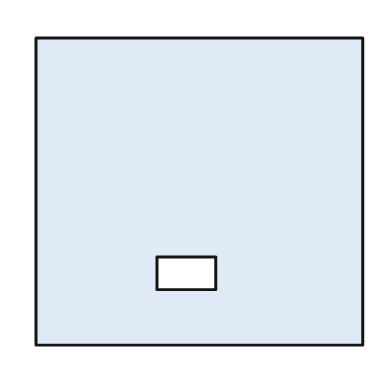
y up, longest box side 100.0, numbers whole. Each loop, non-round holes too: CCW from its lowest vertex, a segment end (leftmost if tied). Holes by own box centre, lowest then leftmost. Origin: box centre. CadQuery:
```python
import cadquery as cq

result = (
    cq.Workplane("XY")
    .moveTo(-50.0, -47.0)
    .lineTo(50.0, -47.0)
    .lineTo(50.0, 47.0)
    .lineTo(-50.0, 47.0)
    .close()
    .moveTo(-13.0, -30.0)
    .lineTo(5.0, -30.0)
    .lineTo(5.0, -20.0)
    .lineTo(-13.0, -20.0)
    .close()
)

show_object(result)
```